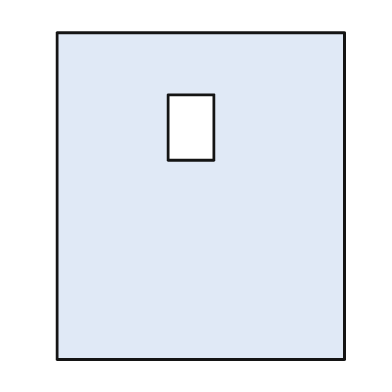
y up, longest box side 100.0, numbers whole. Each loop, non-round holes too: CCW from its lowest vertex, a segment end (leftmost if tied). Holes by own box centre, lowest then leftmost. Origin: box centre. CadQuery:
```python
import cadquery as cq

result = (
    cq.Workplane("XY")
    .moveTo(-44.0, -50.0)
    .lineTo(44.0, -50.0)
    .lineTo(44.0, 50.0)
    .lineTo(-44.0, 50.0)
    .close()
    .moveTo(-10.0, 11.0)
    .lineTo(4.0, 11.0)
    .lineTo(4.0, 31.0)
    .lineTo(-10.0, 31.0)
    .close()
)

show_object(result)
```